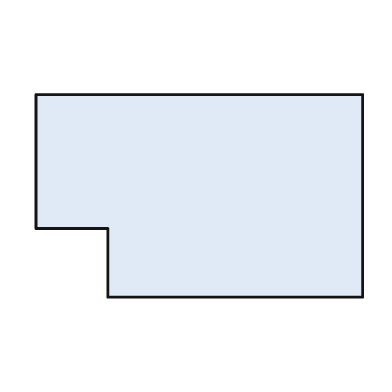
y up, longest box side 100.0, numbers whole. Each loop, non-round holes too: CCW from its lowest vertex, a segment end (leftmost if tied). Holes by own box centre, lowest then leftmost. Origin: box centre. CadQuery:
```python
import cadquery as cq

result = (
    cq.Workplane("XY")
    .moveTo(-28.0, -31.0)
    .lineTo(50.0, -31.0)
    .lineTo(50.0, 31.0)
    .lineTo(-50.0, 31.0)
    .lineTo(-50.0, -10.0)
    .lineTo(-28.0, -10.0)
    .close()
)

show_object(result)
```